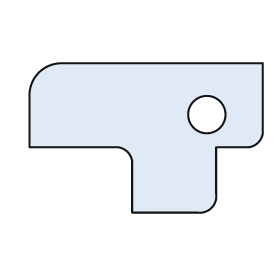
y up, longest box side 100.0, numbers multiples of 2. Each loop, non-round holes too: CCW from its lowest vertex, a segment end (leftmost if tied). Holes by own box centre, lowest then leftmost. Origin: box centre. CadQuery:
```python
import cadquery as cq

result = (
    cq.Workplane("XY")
    .moveTo(-6.0, -32.0)
    .lineTo(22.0, -32.0)
    .threePointArc((28.0, -30.0), (30.0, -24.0))
    .lineTo(30.0, -4.0)
    .lineTo(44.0, -4.0)
    .threePointArc((48.0, -2.0), (50.0, 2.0))
    .lineTo(50.0, 32.0)
    .lineTo(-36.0, 32.0)
    .threePointArc((-46.0, 28.0), (-50.0, 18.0))
    .lineTo(-50.0, -4.0)
    .lineTo(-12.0, -4.0)
    .threePointArc((-8.0, -6.0), (-6.0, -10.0))
    .close()
    .moveTo(26.0, 10.0)
    .circle(8.0)
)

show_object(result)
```